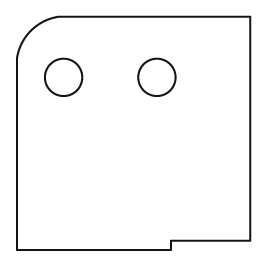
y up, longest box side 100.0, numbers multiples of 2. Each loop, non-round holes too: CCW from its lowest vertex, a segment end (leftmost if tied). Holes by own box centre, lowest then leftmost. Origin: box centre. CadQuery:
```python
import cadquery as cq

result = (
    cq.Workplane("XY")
    .moveTo(-50.0, -50.0)
    .lineTo(16.0, -50.0)
    .lineTo(16.0, -46.0)
    .lineTo(50.0, -46.0)
    .lineTo(50.0, 50.0)
    .lineTo(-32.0, 50.0)
    .threePointArc((-44.0, 44.0), (-50.0, 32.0))
    .close()
    .moveTo(-30.0, 24.0)
    .circle(8.0)
    .moveTo(10.0, 24.0)
    .circle(8.0)
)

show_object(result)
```